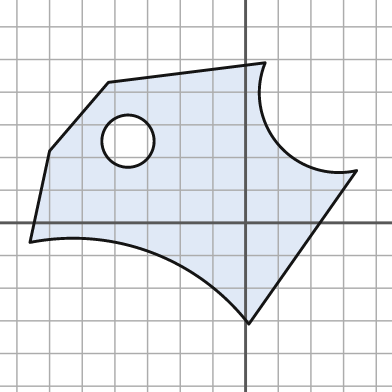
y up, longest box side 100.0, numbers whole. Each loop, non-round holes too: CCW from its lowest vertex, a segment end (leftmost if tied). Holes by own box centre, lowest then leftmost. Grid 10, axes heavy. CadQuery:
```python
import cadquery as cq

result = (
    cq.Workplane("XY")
    .moveTo(1.0, -31.0)
    .lineTo(34.0, 16.0)
    .threePointArc((10.0, 24.0), (6.0, 49.0))
    .lineTo(-42.0, 43.0)
    .lineTo(-60.0, 22.0)
    .lineTo(-66.0, -6.0)
    .threePointArc((-29.0, -9.0), (1.0, -31.0))
    .close()
    .moveTo(-36.0, 25.0)
    .circle(8.0)
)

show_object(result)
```